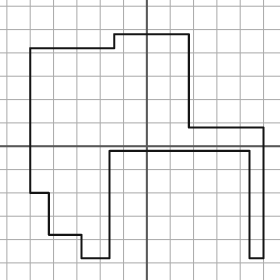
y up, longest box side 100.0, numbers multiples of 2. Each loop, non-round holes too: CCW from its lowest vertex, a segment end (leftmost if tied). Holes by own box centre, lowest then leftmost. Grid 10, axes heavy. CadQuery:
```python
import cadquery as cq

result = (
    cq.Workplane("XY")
    .moveTo(-28.0, -48.0)
    .lineTo(-16.0, -48.0)
    .lineTo(-16.0, -2.0)
    .lineTo(44.0, -2.0)
    .lineTo(44.0, -48.0)
    .lineTo(50.0, -48.0)
    .lineTo(50.0, 8.0)
    .lineTo(18.0, 8.0)
    .lineTo(18.0, 48.0)
    .lineTo(-14.0, 48.0)
    .lineTo(-14.0, 42.0)
    .lineTo(-50.0, 42.0)
    .lineTo(-50.0, -20.0)
    .lineTo(-42.0, -20.0)
    .lineTo(-42.0, -38.0)
    .lineTo(-28.0, -38.0)
    .close()
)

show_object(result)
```